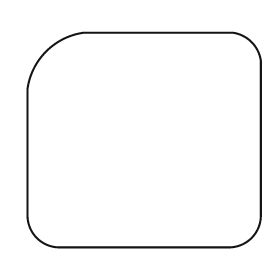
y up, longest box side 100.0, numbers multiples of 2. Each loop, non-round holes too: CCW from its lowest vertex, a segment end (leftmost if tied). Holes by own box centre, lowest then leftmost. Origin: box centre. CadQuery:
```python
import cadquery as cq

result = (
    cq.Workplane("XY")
    .moveTo(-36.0, -46.0)
    .lineTo(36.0, -46.0)
    .threePointArc((46.0, -42.0), (50.0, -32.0))
    .lineTo(50.0, 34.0)
    .threePointArc((46.0, 42.0), (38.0, 46.0))
    .lineTo(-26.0, 46.0)
    .threePointArc((-42.0, 38.0), (-50.0, 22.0))
    .lineTo(-50.0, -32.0)
    .threePointArc((-46.0, -42.0), (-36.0, -46.0))
    .close()
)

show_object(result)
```